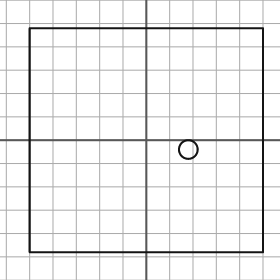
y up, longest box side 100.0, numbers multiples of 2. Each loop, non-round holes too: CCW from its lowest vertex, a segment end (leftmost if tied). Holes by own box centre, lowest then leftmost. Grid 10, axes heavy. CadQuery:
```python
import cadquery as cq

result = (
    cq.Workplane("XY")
    .moveTo(-50.0, -48.0)
    .lineTo(50.0, -48.0)
    .lineTo(50.0, 48.0)
    .lineTo(-50.0, 48.0)
    .close()
    .moveTo(18.0, -4.0)
    .circle(4.0)
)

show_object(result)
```